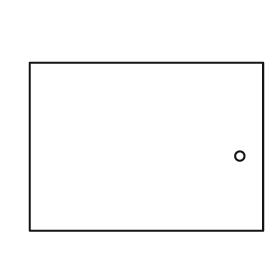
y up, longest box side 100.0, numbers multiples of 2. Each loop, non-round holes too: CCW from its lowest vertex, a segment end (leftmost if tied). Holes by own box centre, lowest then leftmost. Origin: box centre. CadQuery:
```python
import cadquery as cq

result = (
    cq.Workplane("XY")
    .moveTo(-50.0, -36.0)
    .lineTo(50.0, -36.0)
    .lineTo(50.0, 36.0)
    .lineTo(-50.0, 36.0)
    .close()
    .moveTo(40.0, -4.0)
    .circle(2.0)
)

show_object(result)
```